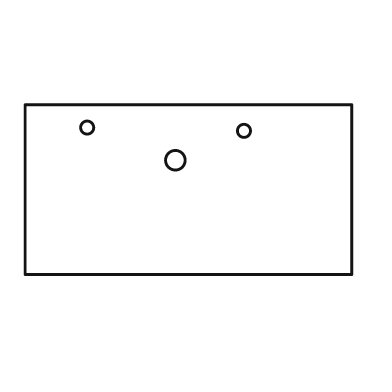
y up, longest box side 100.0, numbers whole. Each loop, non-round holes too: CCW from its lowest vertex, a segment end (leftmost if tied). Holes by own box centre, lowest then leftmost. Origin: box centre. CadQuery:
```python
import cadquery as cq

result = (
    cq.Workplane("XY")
    .moveTo(-50.0, -26.0)
    .lineTo(50.0, -26.0)
    .lineTo(50.0, 26.0)
    .lineTo(-50.0, 26.0)
    .close()
    .moveTo(-4.0, 9.0)
    .circle(3.0)
    .moveTo(17.0, 18.0)
    .circle(2.0)
    .moveTo(-31.0, 19.0)
    .circle(2.0)
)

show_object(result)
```